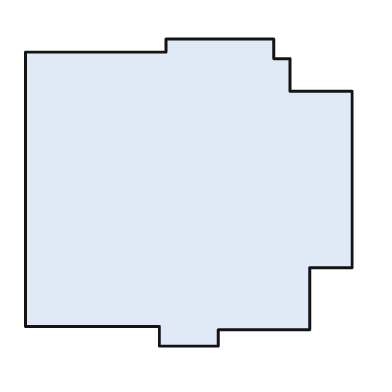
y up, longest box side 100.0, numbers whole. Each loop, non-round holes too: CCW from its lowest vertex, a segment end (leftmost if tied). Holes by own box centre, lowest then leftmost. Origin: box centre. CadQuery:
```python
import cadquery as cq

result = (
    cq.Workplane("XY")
    .moveTo(-9.0, -47.0)
    .lineTo(9.0, -47.0)
    .lineTo(9.0, -42.0)
    .lineTo(37.0, -42.0)
    .lineTo(37.0, -23.0)
    .lineTo(50.0, -23.0)
    .lineTo(50.0, 31.0)
    .lineTo(31.0, 31.0)
    .lineTo(31.0, 41.0)
    .lineTo(26.0, 41.0)
    .lineTo(26.0, 47.0)
    .lineTo(-7.0, 47.0)
    .lineTo(-7.0, 43.0)
    .lineTo(-50.0, 43.0)
    .lineTo(-50.0, -41.0)
    .lineTo(-9.0, -41.0)
    .close()
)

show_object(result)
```